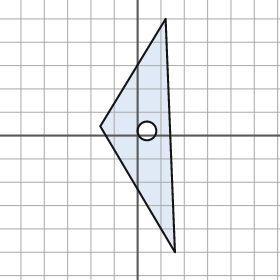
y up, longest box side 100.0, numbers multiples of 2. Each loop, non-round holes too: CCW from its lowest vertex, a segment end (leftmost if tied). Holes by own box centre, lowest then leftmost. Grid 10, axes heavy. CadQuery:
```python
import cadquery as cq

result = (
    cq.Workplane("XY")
    .moveTo(16.0, -50.0)
    .lineTo(12.0, 50.0)
    .lineTo(-16.0, 4.0)
    .close()
    .moveTo(4.0, 2.0)
    .circle(4.0)
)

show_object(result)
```